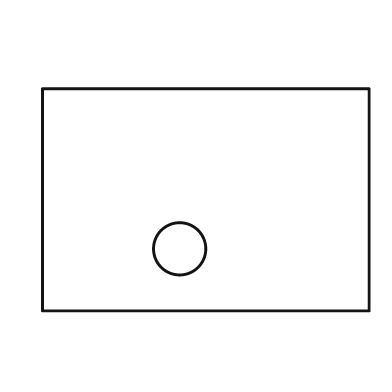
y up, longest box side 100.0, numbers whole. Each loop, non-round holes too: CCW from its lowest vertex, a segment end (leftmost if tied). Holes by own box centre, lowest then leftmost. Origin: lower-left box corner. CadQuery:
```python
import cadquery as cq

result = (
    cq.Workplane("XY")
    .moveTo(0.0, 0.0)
    .lineTo(100.0, 0.0)
    .lineTo(100.0, 68.0)
    .lineTo(0.0, 68.0)
    .close()
    .moveTo(42.0, 19.0)
    .circle(8.0)
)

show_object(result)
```